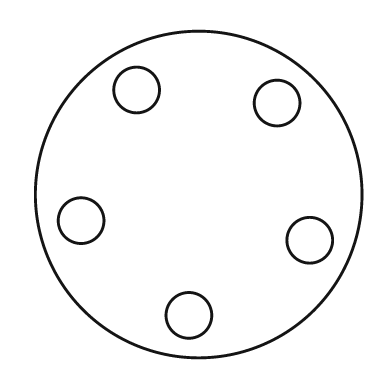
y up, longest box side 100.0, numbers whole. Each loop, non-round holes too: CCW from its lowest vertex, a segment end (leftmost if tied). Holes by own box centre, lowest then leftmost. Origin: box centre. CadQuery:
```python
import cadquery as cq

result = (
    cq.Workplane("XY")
    .moveTo(0.0, 0.0)
    .circle(50.0)
    .moveTo(-3.0, -37.0)
    .circle(7.0)
    .moveTo(34.0, -14.0)
    .circle(7.0)
    .moveTo(-36.0, -8.0)
    .circle(7.0)
    .moveTo(24.0, 28.0)
    .circle(7.0)
    .moveTo(-19.0, 32.0)
    .circle(7.0)
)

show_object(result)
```